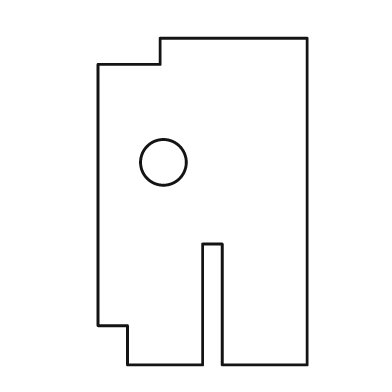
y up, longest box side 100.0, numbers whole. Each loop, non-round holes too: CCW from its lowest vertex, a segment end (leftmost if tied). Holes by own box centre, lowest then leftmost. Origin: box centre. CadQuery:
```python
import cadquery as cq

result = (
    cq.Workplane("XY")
    .moveTo(-23.0, -50.0)
    .lineTo(0.0, -50.0)
    .lineTo(0.0, -13.0)
    .lineTo(6.0, -13.0)
    .lineTo(6.0, -50.0)
    .lineTo(32.0, -50.0)
    .lineTo(32.0, 50.0)
    .lineTo(-13.0, 50.0)
    .lineTo(-13.0, 42.0)
    .lineTo(-32.0, 42.0)
    .lineTo(-32.0, -38.0)
    .lineTo(-23.0, -38.0)
    .close()
    .moveTo(-12.0, 12.0)
    .circle(7.0)
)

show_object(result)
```